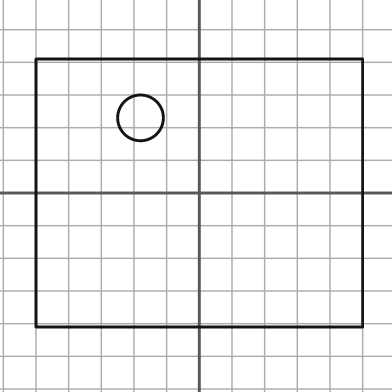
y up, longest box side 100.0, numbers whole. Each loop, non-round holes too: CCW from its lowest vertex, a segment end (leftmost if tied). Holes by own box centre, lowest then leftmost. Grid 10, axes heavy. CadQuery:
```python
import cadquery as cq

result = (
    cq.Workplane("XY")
    .moveTo(-50.0, -41.0)
    .lineTo(50.0, -41.0)
    .lineTo(50.0, 41.0)
    .lineTo(-50.0, 41.0)
    .close()
    .moveTo(-18.0, 23.0)
    .circle(7.0)
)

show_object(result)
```